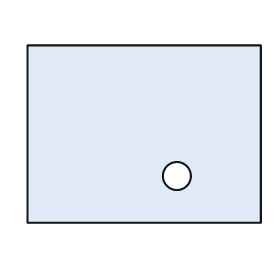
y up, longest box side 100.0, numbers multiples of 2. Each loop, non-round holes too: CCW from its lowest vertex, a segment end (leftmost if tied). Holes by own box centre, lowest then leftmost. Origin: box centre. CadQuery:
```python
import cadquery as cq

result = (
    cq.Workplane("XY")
    .moveTo(-50.0, -38.0)
    .lineTo(50.0, -38.0)
    .lineTo(50.0, 38.0)
    .lineTo(-50.0, 38.0)
    .close()
    .moveTo(14.0, -18.0)
    .circle(6.0)
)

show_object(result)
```